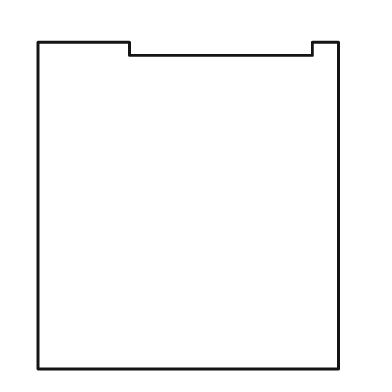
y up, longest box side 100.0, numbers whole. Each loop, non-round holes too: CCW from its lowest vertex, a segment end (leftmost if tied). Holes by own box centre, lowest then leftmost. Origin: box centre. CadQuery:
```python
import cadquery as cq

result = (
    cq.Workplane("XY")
    .moveTo(-46.0, -50.0)
    .lineTo(46.0, -50.0)
    .lineTo(46.0, 50.0)
    .lineTo(38.0, 50.0)
    .lineTo(38.0, 46.0)
    .lineTo(-18.0, 46.0)
    .lineTo(-18.0, 50.0)
    .lineTo(-46.0, 50.0)
    .close()
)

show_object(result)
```